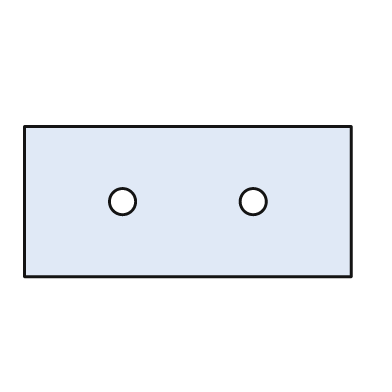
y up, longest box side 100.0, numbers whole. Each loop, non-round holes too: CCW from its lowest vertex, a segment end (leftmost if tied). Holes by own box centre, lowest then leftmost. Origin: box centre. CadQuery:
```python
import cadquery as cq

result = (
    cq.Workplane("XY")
    .moveTo(-50.0, -23.0)
    .lineTo(50.0, -23.0)
    .lineTo(50.0, 23.0)
    .lineTo(-50.0, 23.0)
    .close()
    .moveTo(-20.0, 0.0)
    .circle(4.0)
    .moveTo(20.0, 0.0)
    .circle(4.0)
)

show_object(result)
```